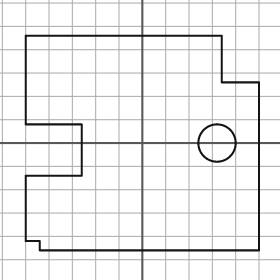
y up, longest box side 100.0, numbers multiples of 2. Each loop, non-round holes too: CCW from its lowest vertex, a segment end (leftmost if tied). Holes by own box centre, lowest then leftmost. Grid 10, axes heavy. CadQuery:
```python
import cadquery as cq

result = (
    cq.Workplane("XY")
    .moveTo(-44.0, -46.0)
    .lineTo(50.0, -46.0)
    .lineTo(50.0, 26.0)
    .lineTo(34.0, 26.0)
    .lineTo(34.0, 46.0)
    .lineTo(-50.0, 46.0)
    .lineTo(-50.0, 8.0)
    .lineTo(-26.0, 8.0)
    .lineTo(-26.0, -14.0)
    .lineTo(-50.0, -14.0)
    .lineTo(-50.0, -42.0)
    .lineTo(-44.0, -42.0)
    .close()
    .moveTo(32.0, 0.0)
    .circle(8.0)
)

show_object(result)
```